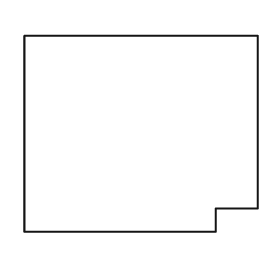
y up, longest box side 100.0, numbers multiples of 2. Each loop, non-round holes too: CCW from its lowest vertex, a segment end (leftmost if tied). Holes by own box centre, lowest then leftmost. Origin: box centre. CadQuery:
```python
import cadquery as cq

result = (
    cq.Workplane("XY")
    .moveTo(-50.0, -42.0)
    .lineTo(32.0, -42.0)
    .lineTo(32.0, -32.0)
    .lineTo(50.0, -32.0)
    .lineTo(50.0, 42.0)
    .lineTo(-50.0, 42.0)
    .close()
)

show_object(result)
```